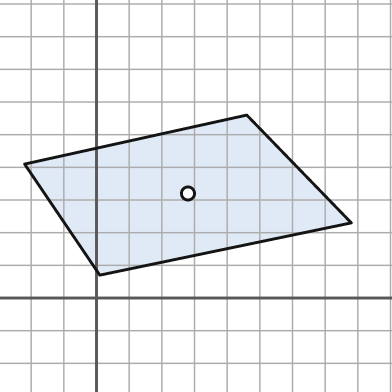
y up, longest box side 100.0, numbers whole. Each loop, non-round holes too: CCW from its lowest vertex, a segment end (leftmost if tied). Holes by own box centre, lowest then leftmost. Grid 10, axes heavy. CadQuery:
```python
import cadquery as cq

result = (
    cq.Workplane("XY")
    .moveTo(1.0, 7.0)
    .lineTo(78.0, 23.0)
    .lineTo(46.0, 56.0)
    .lineTo(-22.0, 41.0)
    .close()
    .moveTo(28.0, 32.0)
    .circle(2.0)
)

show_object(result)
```